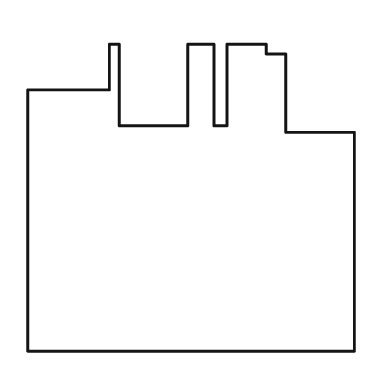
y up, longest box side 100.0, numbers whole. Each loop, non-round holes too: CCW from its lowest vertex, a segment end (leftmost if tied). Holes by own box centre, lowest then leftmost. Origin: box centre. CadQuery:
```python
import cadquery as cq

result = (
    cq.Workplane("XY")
    .moveTo(-50.0, -47.0)
    .lineTo(50.0, -47.0)
    .lineTo(50.0, 20.0)
    .lineTo(29.0, 20.0)
    .lineTo(29.0, 44.0)
    .lineTo(23.0, 44.0)
    .lineTo(23.0, 47.0)
    .lineTo(11.0, 47.0)
    .lineTo(11.0, 22.0)
    .lineTo(7.0, 22.0)
    .lineTo(7.0, 47.0)
    .lineTo(-1.0, 47.0)
    .lineTo(-1.0, 22.0)
    .lineTo(-22.0, 22.0)
    .lineTo(-22.0, 47.0)
    .lineTo(-25.0, 47.0)
    .lineTo(-25.0, 33.0)
    .lineTo(-50.0, 33.0)
    .close()
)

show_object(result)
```